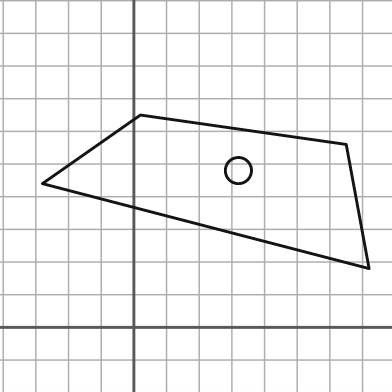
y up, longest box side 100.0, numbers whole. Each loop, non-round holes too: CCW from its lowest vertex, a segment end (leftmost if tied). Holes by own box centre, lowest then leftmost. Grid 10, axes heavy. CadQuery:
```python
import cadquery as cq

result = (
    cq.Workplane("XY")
    .moveTo(72.0, 18.0)
    .lineTo(65.0, 56.0)
    .lineTo(2.0, 65.0)
    .lineTo(-28.0, 44.0)
    .close()
    .moveTo(32.0, 48.0)
    .circle(4.0)
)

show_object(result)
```